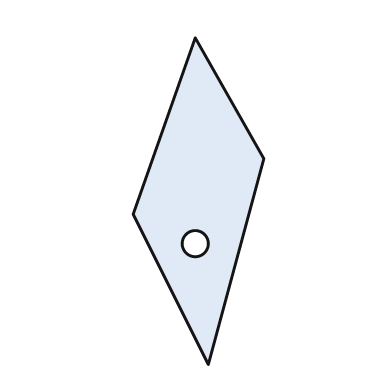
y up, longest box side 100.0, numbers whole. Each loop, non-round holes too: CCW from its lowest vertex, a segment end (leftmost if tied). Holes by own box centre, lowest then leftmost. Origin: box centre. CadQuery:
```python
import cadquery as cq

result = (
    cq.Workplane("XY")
    .moveTo(3.0, -50.0)
    .lineTo(20.0, 13.0)
    .lineTo(-1.0, 50.0)
    .lineTo(-20.0, -4.0)
    .close()
    .moveTo(-1.0, -13.0)
    .circle(4.0)
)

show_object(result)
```